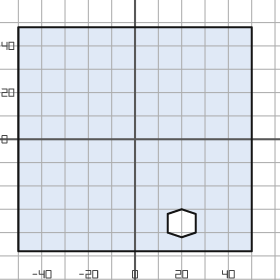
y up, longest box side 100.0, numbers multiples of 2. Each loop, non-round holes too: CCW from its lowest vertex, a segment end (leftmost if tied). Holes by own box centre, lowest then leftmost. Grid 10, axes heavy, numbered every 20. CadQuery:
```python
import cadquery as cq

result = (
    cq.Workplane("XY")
    .moveTo(-50.0, -48.0)
    .lineTo(50.0, -48.0)
    .lineTo(50.0, 48.0)
    .lineTo(-50.0, 48.0)
    .close()
    .moveTo(20.0, -42.0)
    .lineTo(26.0, -40.0)
    .lineTo(26.0, -32.0)
    .lineTo(20.0, -30.0)
    .lineTo(14.0, -32.0)
    .lineTo(14.0, -40.0)
    .close()
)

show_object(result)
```